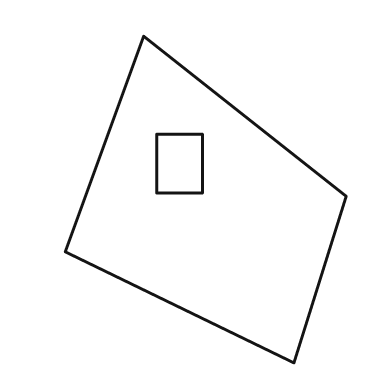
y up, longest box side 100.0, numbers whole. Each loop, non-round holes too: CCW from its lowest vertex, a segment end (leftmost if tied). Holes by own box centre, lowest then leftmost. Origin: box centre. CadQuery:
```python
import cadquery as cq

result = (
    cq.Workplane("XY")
    .moveTo(27.0, -50.0)
    .lineTo(43.0, 1.0)
    .lineTo(-19.0, 50.0)
    .lineTo(-43.0, -16.0)
    .close()
    .moveTo(-15.0, 2.0)
    .lineTo(-1.0, 2.0)
    .lineTo(-1.0, 20.0)
    .lineTo(-15.0, 20.0)
    .close()
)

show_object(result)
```